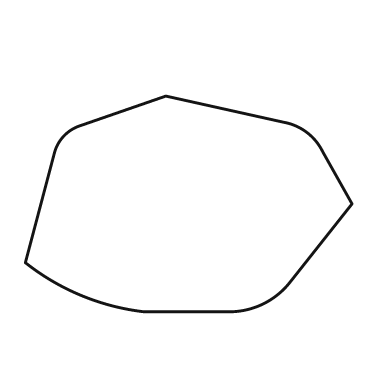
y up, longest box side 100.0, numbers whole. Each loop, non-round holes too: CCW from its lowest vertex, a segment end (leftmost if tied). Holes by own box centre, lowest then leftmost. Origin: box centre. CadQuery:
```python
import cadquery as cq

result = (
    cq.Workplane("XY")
    .moveTo(-14.0, -33.0)
    .lineTo(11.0, -33.0)
    .threePointArc((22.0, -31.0), (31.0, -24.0))
    .lineTo(50.0, 0.0)
    .lineTo(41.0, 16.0)
    .threePointArc((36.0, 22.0), (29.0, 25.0))
    .lineTo(-7.0, 33.0)
    .lineTo(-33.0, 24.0)
    .threePointArc((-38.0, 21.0), (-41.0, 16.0))
    .lineTo(-50.0, -18.0)
    .threePointArc((-33.0, -28.0), (-14.0, -33.0))
    .close()
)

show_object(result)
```